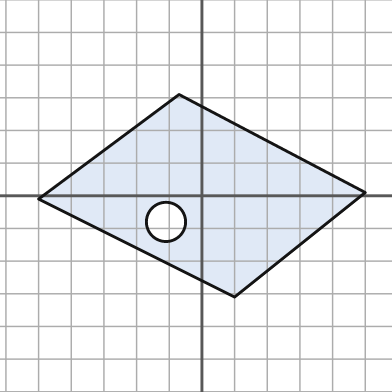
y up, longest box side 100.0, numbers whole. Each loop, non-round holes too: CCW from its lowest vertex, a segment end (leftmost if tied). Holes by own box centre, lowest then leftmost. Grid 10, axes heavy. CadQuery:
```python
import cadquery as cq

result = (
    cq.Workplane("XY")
    .moveTo(10.0, -31.0)
    .lineTo(50.0, 1.0)
    .lineTo(-7.0, 31.0)
    .lineTo(-50.0, -1.0)
    .close()
    .moveTo(-11.0, -8.0)
    .circle(6.0)
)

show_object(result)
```